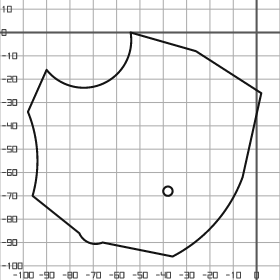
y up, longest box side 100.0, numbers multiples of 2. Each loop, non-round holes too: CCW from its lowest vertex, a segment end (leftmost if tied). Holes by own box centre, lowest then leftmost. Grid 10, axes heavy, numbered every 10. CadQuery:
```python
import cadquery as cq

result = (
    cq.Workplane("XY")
    .moveTo(-36.0, -96.0)
    .threePointArc((-18.0, -82.0), (-6.0, -62.0))
    .lineTo(2.0, -26.0)
    .lineTo(-26.0, -8.0)
    .lineTo(-54.0, 0.0)
    .threePointArc((-66.0, -22.0), (-90.0, -16.0))
    .lineTo(-98.0, -34.0)
    .threePointArc((-94.0, -52.0), (-96.0, -70.0))
    .lineTo(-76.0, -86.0)
    .threePointArc((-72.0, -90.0), (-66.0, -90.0))
    .close()
    .moveTo(-38.0, -68.0)
    .circle(2.0)
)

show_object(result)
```